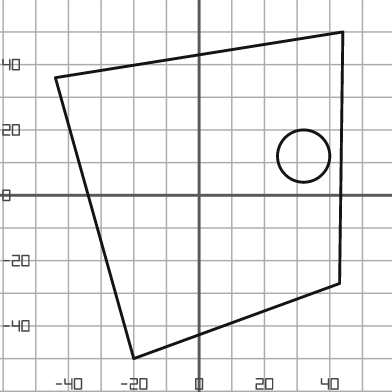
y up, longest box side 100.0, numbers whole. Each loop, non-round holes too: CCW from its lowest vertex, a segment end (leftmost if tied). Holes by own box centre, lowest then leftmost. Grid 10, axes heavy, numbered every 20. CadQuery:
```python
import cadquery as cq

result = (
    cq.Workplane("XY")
    .moveTo(-20.0, -50.0)
    .lineTo(43.0, -27.0)
    .lineTo(44.0, 50.0)
    .lineTo(-44.0, 36.0)
    .close()
    .moveTo(32.0, 12.0)
    .circle(8.0)
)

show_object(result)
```